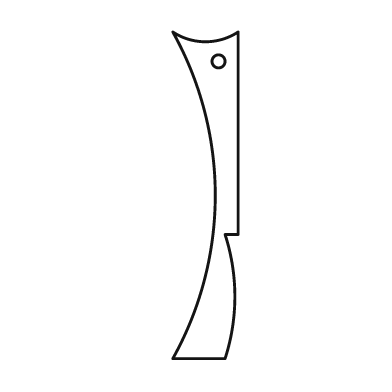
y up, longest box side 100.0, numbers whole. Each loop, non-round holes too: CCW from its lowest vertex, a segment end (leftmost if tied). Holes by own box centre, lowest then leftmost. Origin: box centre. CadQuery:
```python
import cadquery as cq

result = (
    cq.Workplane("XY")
    .moveTo(-10.0, -50.0)
    .lineTo(6.0, -50.0)
    .threePointArc((9.0, -31.0), (6.0, -12.0))
    .lineTo(10.0, -12.0)
    .lineTo(10.0, 50.0)
    .threePointArc((0.0, 47.0), (-10.0, 50.0))
    .threePointArc((3.0, 0.0), (-10.0, -50.0))
    .close()
    .moveTo(4.0, 41.0)
    .circle(2.0)
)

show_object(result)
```